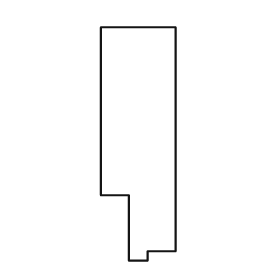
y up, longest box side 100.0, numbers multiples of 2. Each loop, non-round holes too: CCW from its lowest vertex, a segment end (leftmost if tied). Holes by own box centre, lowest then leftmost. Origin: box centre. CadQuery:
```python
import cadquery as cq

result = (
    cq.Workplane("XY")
    .moveTo(-4.0, -50.0)
    .lineTo(4.0, -50.0)
    .lineTo(4.0, -46.0)
    .lineTo(16.0, -46.0)
    .lineTo(16.0, 50.0)
    .lineTo(-16.0, 50.0)
    .lineTo(-16.0, -22.0)
    .lineTo(-4.0, -22.0)
    .close()
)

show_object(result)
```